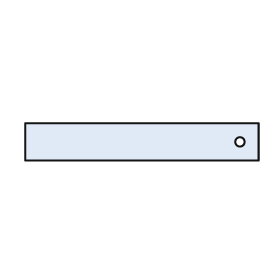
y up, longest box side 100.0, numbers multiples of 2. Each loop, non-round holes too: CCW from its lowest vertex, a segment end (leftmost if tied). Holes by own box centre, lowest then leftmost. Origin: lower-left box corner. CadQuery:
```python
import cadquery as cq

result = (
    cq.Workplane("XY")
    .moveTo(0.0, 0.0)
    .lineTo(100.0, 0.0)
    .lineTo(100.0, 16.0)
    .lineTo(0.0, 16.0)
    .close()
    .moveTo(92.0, 8.0)
    .circle(2.0)
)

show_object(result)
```